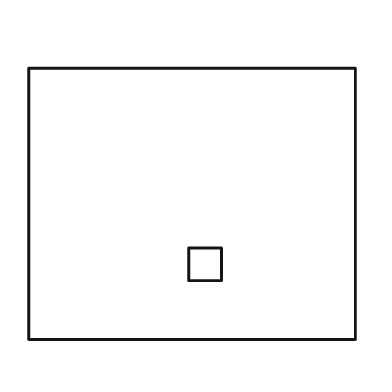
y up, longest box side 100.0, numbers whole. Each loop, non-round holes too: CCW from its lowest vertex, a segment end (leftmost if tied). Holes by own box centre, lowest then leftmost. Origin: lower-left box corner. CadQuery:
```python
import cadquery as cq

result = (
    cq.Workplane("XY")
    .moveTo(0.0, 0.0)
    .lineTo(100.0, 0.0)
    .lineTo(100.0, 83.0)
    .lineTo(0.0, 83.0)
    .close()
    .moveTo(49.0, 18.0)
    .lineTo(59.0, 18.0)
    .lineTo(59.0, 28.0)
    .lineTo(49.0, 28.0)
    .close()
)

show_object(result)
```